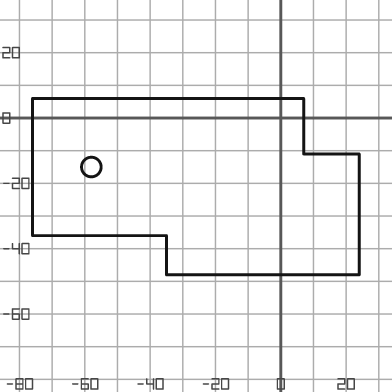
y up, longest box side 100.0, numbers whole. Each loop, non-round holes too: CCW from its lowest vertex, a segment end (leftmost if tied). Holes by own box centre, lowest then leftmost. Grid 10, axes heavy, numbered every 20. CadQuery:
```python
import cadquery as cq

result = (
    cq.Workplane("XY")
    .moveTo(-35.0, -48.0)
    .lineTo(24.0, -48.0)
    .lineTo(24.0, -11.0)
    .lineTo(7.0, -11.0)
    .lineTo(7.0, 6.0)
    .lineTo(-76.0, 6.0)
    .lineTo(-76.0, -36.0)
    .lineTo(-35.0, -36.0)
    .close()
    .moveTo(-58.0, -15.0)
    .circle(3.0)
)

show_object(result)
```